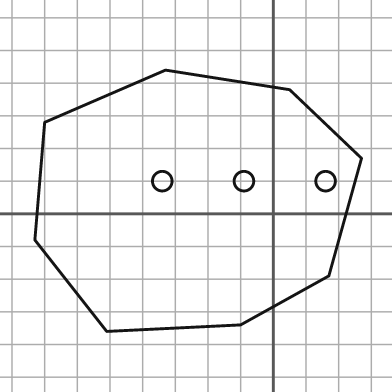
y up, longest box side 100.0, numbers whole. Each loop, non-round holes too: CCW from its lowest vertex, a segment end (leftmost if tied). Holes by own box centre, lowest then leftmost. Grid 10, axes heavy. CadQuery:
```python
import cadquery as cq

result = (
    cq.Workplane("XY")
    .moveTo(-51.0, -36.0)
    .lineTo(-10.0, -34.0)
    .lineTo(17.0, -19.0)
    .lineTo(27.0, 17.0)
    .lineTo(5.0, 38.0)
    .lineTo(-33.0, 44.0)
    .lineTo(-70.0, 28.0)
    .lineTo(-73.0, -8.0)
    .close()
    .moveTo(-34.0, 10.0)
    .circle(3.0)
    .moveTo(-9.0, 10.0)
    .circle(3.0)
    .moveTo(16.0, 10.0)
    .circle(3.0)
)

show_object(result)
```